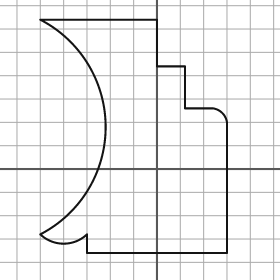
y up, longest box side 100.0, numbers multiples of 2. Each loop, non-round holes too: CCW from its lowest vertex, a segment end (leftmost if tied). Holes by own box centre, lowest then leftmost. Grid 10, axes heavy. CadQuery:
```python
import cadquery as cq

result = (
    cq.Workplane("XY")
    .moveTo(-30.0, -36.0)
    .lineTo(30.0, -36.0)
    .lineTo(30.0, 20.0)
    .threePointArc((28.0, 24.0), (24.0, 26.0))
    .lineTo(12.0, 26.0)
    .lineTo(12.0, 44.0)
    .lineTo(0.0, 44.0)
    .lineTo(0.0, 64.0)
    .lineTo(-50.0, 64.0)
    .threePointArc((-22.0, 18.0), (-50.0, -28.0))
    .threePointArc((-40.0, -32.0), (-30.0, -28.0))
    .close()
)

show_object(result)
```